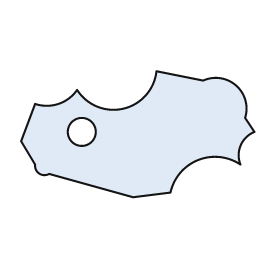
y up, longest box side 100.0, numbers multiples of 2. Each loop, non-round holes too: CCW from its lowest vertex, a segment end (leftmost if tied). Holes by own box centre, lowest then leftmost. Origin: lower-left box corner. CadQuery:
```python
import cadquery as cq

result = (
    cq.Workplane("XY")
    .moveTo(48.0, 0.0)
    .lineTo(64.0, 2.0)
    .threePointArc((76.0, 16.0), (94.0, 14.0))
    .threePointArc((94.0, 22.0), (100.0, 28.0))
    .lineTo(96.0, 34.0)
    .threePointArc((92.0, 48.0), (78.0, 50.0))
    .lineTo(58.0, 54.0)
    .threePointArc((44.0, 38.0), (24.0, 46.0))
    .threePointArc((16.0, 40.0), (6.0, 40.0))
    .lineTo(0.0, 24.0)
    .lineTo(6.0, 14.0)
    .threePointArc((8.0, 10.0), (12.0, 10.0))
    .close()
    .moveTo(26.0, 28.0)
    .circle(6.0)
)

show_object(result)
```